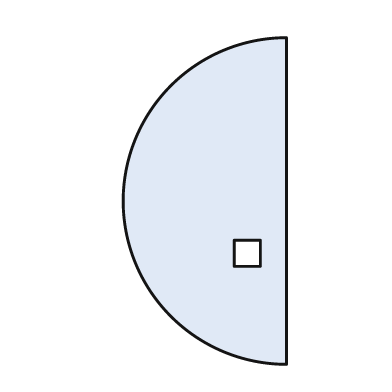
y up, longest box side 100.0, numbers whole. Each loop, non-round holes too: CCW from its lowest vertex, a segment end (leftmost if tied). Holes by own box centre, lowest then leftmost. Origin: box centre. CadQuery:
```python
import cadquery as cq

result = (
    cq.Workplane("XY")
    .moveTo(25.0, -50.0)
    .lineTo(25.0, 50.0)
    .threePointArc((-25.0, 0.0), (25.0, -50.0))
    .close()
    .moveTo(9.0, -20.0)
    .lineTo(17.0, -20.0)
    .lineTo(17.0, -12.0)
    .lineTo(9.0, -12.0)
    .close()
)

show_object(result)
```